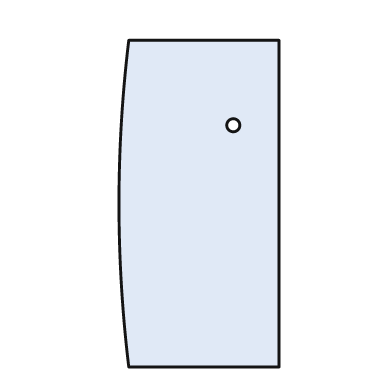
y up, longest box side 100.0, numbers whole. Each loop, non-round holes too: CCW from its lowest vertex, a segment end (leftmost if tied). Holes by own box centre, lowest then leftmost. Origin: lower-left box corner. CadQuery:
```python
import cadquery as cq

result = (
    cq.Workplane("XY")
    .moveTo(3.0, 0.0)
    .lineTo(49.0, 0.0)
    .lineTo(49.0, 100.0)
    .lineTo(3.0, 100.0)
    .threePointArc((0.0, 50.0), (3.0, 0.0))
    .close()
    .moveTo(35.0, 74.0)
    .circle(2.0)
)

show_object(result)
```